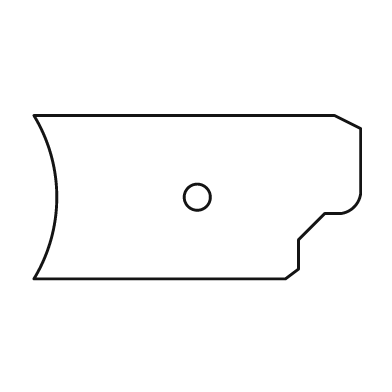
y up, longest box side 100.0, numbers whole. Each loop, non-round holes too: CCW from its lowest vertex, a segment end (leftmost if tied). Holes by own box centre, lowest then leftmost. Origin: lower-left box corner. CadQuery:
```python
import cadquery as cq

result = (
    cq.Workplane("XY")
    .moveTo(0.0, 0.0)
    .lineTo(77.0, 0.0)
    .lineTo(81.0, 3.0)
    .lineTo(81.0, 12.0)
    .lineTo(89.0, 20.0)
    .lineTo(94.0, 20.0)
    .threePointArc((98.0, 22.0), (100.0, 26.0))
    .lineTo(100.0, 46.0)
    .lineTo(92.0, 50.0)
    .lineTo(0.0, 50.0)
    .threePointArc((7.0, 25.0), (0.0, 0.0))
    .close()
    .moveTo(50.0, 25.0)
    .circle(4.0)
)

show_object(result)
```